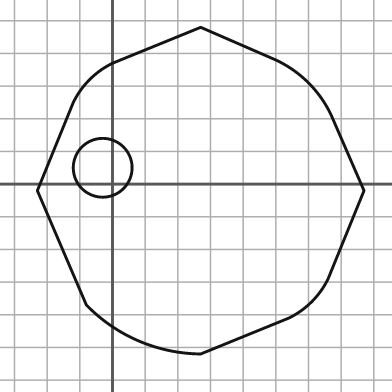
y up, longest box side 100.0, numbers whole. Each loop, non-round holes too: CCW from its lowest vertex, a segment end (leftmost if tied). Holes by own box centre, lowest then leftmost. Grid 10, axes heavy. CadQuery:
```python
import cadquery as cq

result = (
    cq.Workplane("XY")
    .moveTo(27.0, -52.0)
    .lineTo(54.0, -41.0)
    .threePointArc((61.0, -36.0), (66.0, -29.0))
    .lineTo(77.0, -2.0)
    .lineTo(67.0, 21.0)
    .threePointArc((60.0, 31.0), (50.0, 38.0))
    .lineTo(27.0, 48.0)
    .lineTo(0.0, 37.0)
    .threePointArc((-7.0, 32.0), (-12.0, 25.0))
    .lineTo(-23.0, -2.0)
    .lineTo(-8.0, -37.0)
    .threePointArc((8.0, -48.0), (27.0, -52.0))
    .close()
    .moveTo(-3.0, 5.0)
    .circle(9.0)
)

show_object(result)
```